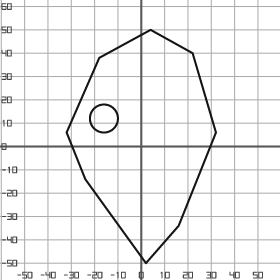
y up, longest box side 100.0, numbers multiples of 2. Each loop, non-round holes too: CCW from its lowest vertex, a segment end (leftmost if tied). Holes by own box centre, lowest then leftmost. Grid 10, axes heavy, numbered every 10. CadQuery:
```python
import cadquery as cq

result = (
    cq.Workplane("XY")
    .moveTo(2.0, -50.0)
    .lineTo(16.0, -34.0)
    .lineTo(32.0, 6.0)
    .lineTo(22.0, 40.0)
    .lineTo(4.0, 50.0)
    .lineTo(-18.0, 38.0)
    .lineTo(-32.0, 6.0)
    .lineTo(-24.0, -14.0)
    .close()
    .moveTo(-16.0, 12.0)
    .circle(6.0)
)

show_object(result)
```